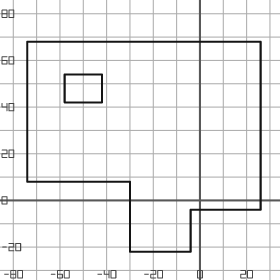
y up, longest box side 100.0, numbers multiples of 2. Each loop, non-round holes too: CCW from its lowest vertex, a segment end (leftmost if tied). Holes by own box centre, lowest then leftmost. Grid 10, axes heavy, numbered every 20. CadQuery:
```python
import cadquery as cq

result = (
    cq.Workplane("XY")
    .moveTo(-30.0, -22.0)
    .lineTo(-4.0, -22.0)
    .lineTo(-4.0, -4.0)
    .lineTo(26.0, -4.0)
    .lineTo(26.0, 68.0)
    .lineTo(-74.0, 68.0)
    .lineTo(-74.0, 8.0)
    .lineTo(-30.0, 8.0)
    .close()
    .moveTo(-58.0, 42.0)
    .lineTo(-42.0, 42.0)
    .lineTo(-42.0, 54.0)
    .lineTo(-58.0, 54.0)
    .close()
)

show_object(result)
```